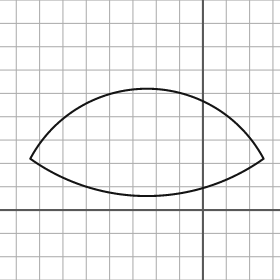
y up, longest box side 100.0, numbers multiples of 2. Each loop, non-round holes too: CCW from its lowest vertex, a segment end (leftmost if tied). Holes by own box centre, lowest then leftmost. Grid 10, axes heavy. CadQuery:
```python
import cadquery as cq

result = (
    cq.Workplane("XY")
    .moveTo(-74.0, 22.0)
    .threePointArc((-24.0, 6.0), (26.0, 22.0))
    .threePointArc((-24.0, 52.0), (-74.0, 22.0))
    .close()
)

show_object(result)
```